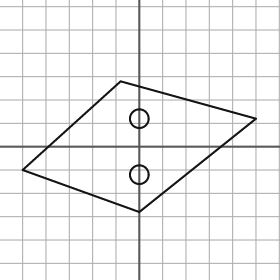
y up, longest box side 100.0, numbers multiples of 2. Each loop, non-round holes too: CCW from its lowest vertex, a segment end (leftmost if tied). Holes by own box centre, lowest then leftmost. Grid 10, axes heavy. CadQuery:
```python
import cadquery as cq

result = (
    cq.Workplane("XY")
    .moveTo(0.0, -28.0)
    .lineTo(50.0, 12.0)
    .lineTo(-8.0, 28.0)
    .lineTo(-50.0, -10.0)
    .close()
    .moveTo(0.0, -12.0)
    .circle(4.0)
    .moveTo(0.0, 12.0)
    .circle(4.0)
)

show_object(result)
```